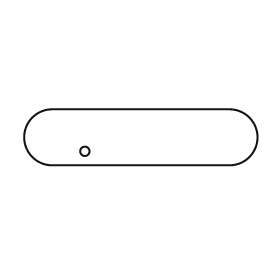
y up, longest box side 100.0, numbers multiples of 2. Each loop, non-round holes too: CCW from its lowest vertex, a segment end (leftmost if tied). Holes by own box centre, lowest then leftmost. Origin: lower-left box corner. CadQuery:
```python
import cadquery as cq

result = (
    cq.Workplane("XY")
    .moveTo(12.0, 0.0)
    .lineTo(88.0, 0.0)
    .threePointArc((100.0, 12.0), (88.0, 24.0))
    .lineTo(12.0, 24.0)
    .threePointArc((0.0, 12.0), (12.0, 0.0))
    .close()
    .moveTo(26.0, 6.0)
    .circle(2.0)
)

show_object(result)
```